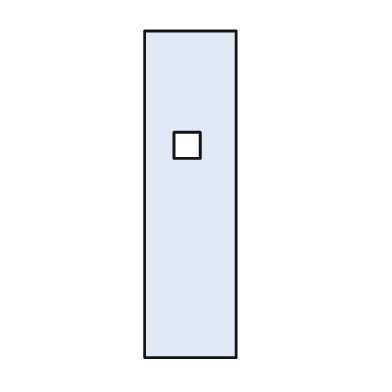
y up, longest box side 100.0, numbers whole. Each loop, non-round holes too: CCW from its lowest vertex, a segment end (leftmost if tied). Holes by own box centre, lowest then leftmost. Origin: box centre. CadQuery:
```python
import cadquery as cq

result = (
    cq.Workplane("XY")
    .moveTo(-14.0, -50.0)
    .lineTo(14.0, -50.0)
    .lineTo(14.0, 50.0)
    .lineTo(-14.0, 50.0)
    .close()
    .moveTo(-5.0, 11.0)
    .lineTo(3.0, 11.0)
    .lineTo(3.0, 19.0)
    .lineTo(-5.0, 19.0)
    .close()
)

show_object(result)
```